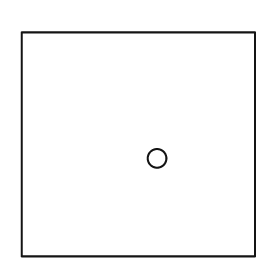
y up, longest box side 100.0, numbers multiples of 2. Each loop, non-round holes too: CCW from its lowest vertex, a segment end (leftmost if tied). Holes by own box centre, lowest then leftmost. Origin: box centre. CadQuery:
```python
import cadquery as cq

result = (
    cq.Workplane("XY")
    .moveTo(-50.0, -48.0)
    .lineTo(50.0, -48.0)
    .lineTo(50.0, 48.0)
    .lineTo(-50.0, 48.0)
    .close()
    .moveTo(8.0, -6.0)
    .circle(4.0)
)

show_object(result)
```